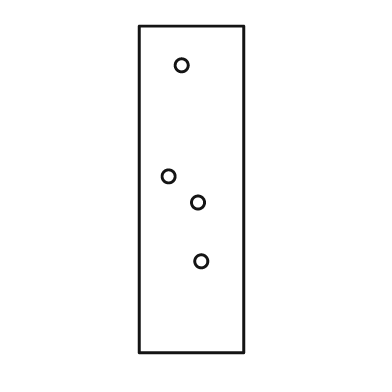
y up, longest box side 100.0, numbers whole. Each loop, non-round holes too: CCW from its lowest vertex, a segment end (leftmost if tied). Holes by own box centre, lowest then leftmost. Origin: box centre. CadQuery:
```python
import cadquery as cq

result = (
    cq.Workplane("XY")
    .moveTo(-16.0, -50.0)
    .lineTo(16.0, -50.0)
    .lineTo(16.0, 50.0)
    .lineTo(-16.0, 50.0)
    .close()
    .moveTo(3.0, -22.0)
    .circle(2.0)
    .moveTo(2.0, -4.0)
    .circle(2.0)
    .moveTo(-7.0, 4.0)
    .circle(2.0)
    .moveTo(-3.0, 38.0)
    .circle(2.0)
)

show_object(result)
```